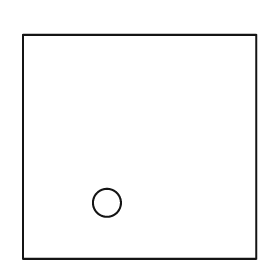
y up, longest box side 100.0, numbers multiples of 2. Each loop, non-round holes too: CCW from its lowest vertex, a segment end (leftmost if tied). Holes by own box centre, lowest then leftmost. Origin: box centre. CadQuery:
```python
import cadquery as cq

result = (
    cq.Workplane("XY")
    .moveTo(-50.0, -48.0)
    .lineTo(50.0, -48.0)
    .lineTo(50.0, 48.0)
    .lineTo(-50.0, 48.0)
    .close()
    .moveTo(-14.0, -24.0)
    .circle(6.0)
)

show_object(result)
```